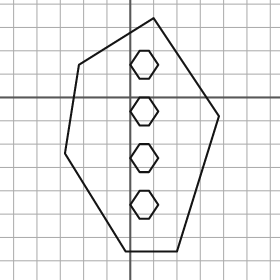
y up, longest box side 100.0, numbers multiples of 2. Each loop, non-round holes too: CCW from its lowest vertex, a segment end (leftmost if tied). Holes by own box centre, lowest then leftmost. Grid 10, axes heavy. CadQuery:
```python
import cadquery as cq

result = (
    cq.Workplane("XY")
    .moveTo(-2.0, -66.0)
    .lineTo(20.0, -66.0)
    .lineTo(38.0, -8.0)
    .lineTo(10.0, 34.0)
    .lineTo(-22.0, 14.0)
    .lineTo(-28.0, -24.0)
    .close()
    .moveTo(4.0, -52.0)
    .lineTo(8.0, -52.0)
    .lineTo(12.0, -46.0)
    .lineTo(8.0, -40.0)
    .lineTo(4.0, -40.0)
    .lineTo(0.0, -46.0)
    .close()
    .moveTo(4.0, -32.0)
    .lineTo(8.0, -32.0)
    .lineTo(12.0, -26.0)
    .lineTo(8.0, -20.0)
    .lineTo(4.0, -20.0)
    .lineTo(0.0, -26.0)
    .close()
    .moveTo(4.0, -12.0)
    .lineTo(8.0, -12.0)
    .lineTo(12.0, -6.0)
    .lineTo(8.0, 0.0)
    .lineTo(4.0, 0.0)
    .lineTo(0.0, -6.0)
    .close()
    .moveTo(4.0, 8.0)
    .lineTo(8.0, 8.0)
    .lineTo(12.0, 14.0)
    .lineTo(8.0, 20.0)
    .lineTo(4.0, 20.0)
    .lineTo(0.0, 14.0)
    .close()
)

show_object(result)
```